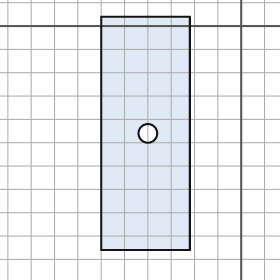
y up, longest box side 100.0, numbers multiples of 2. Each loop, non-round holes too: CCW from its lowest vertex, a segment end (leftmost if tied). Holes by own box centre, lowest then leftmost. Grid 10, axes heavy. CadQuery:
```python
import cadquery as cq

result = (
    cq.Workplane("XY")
    .moveTo(-60.0, -96.0)
    .lineTo(-22.0, -96.0)
    .lineTo(-22.0, 4.0)
    .lineTo(-60.0, 4.0)
    .close()
    .moveTo(-40.0, -46.0)
    .circle(4.0)
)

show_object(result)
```